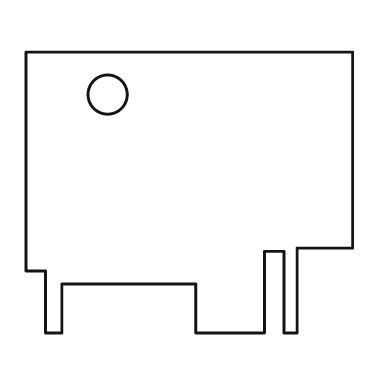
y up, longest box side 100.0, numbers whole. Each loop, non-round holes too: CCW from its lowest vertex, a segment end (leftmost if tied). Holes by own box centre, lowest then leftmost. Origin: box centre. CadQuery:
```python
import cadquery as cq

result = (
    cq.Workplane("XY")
    .moveTo(-44.0, -43.0)
    .lineTo(-39.0, -43.0)
    .lineTo(-39.0, -28.0)
    .lineTo(2.0, -28.0)
    .lineTo(2.0, -43.0)
    .lineTo(23.0, -43.0)
    .lineTo(23.0, -18.0)
    .lineTo(29.0, -18.0)
    .lineTo(29.0, -43.0)
    .lineTo(33.0, -43.0)
    .lineTo(33.0, -17.0)
    .lineTo(50.0, -17.0)
    .lineTo(50.0, 43.0)
    .lineTo(-50.0, 43.0)
    .lineTo(-50.0, -24.0)
    .lineTo(-44.0, -24.0)
    .close()
    .moveTo(-25.0, 30.0)
    .circle(6.0)
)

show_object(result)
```